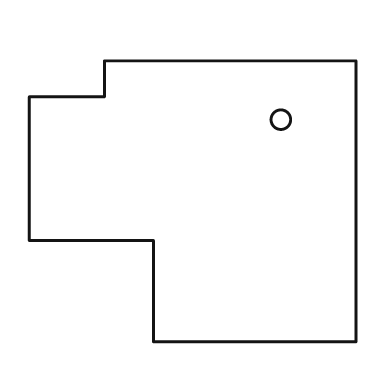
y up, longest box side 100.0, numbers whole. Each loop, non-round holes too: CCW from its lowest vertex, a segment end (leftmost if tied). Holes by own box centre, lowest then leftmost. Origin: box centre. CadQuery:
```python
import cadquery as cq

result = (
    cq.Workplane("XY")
    .moveTo(-12.0, -43.0)
    .lineTo(50.0, -43.0)
    .lineTo(50.0, 43.0)
    .lineTo(-27.0, 43.0)
    .lineTo(-27.0, 32.0)
    .lineTo(-50.0, 32.0)
    .lineTo(-50.0, -12.0)
    .lineTo(-12.0, -12.0)
    .close()
    .moveTo(27.0, 25.0)
    .circle(3.0)
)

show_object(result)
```